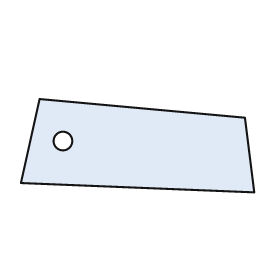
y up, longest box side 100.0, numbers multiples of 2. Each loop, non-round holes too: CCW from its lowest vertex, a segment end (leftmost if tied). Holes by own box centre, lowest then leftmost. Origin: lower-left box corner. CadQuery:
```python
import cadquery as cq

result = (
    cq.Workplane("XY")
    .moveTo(100.0, 0.0)
    .lineTo(96.0, 32.0)
    .lineTo(8.0, 40.0)
    .lineTo(0.0, 4.0)
    .close()
    .moveTo(18.0, 22.0)
    .circle(4.0)
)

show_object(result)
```